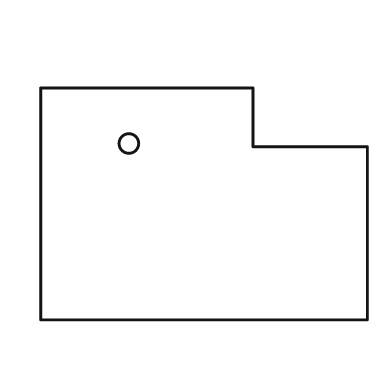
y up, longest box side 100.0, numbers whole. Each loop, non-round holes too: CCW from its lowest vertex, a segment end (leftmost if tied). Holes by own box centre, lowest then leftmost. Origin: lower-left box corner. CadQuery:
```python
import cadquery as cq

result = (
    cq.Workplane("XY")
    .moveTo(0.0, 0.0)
    .lineTo(100.0, 0.0)
    .lineTo(100.0, 53.0)
    .lineTo(65.0, 53.0)
    .lineTo(65.0, 71.0)
    .lineTo(0.0, 71.0)
    .close()
    .moveTo(27.0, 54.0)
    .circle(3.0)
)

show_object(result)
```